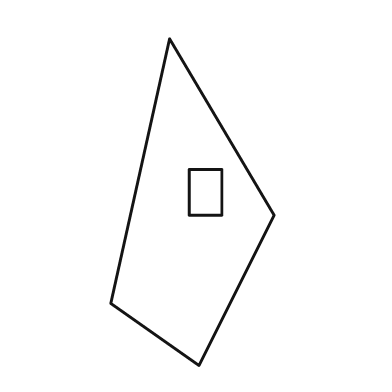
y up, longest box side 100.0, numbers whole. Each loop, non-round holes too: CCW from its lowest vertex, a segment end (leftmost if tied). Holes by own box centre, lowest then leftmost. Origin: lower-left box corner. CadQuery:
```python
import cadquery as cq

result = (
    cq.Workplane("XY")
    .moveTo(27.0, 0.0)
    .lineTo(50.0, 46.0)
    .lineTo(18.0, 100.0)
    .lineTo(0.0, 19.0)
    .close()
    .moveTo(24.0, 46.0)
    .lineTo(34.0, 46.0)
    .lineTo(34.0, 60.0)
    .lineTo(24.0, 60.0)
    .close()
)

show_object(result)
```